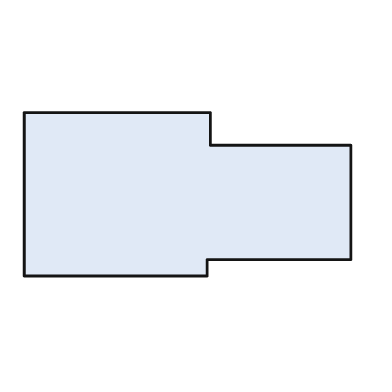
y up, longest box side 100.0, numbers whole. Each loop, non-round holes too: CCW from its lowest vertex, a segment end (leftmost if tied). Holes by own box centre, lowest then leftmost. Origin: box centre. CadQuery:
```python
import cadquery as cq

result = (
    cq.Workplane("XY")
    .moveTo(-50.0, -25.0)
    .lineTo(6.0, -25.0)
    .lineTo(6.0, -20.0)
    .lineTo(50.0, -20.0)
    .lineTo(50.0, 15.0)
    .lineTo(7.0, 15.0)
    .lineTo(7.0, 25.0)
    .lineTo(-50.0, 25.0)
    .close()
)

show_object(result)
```